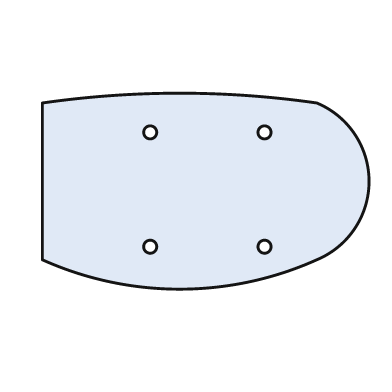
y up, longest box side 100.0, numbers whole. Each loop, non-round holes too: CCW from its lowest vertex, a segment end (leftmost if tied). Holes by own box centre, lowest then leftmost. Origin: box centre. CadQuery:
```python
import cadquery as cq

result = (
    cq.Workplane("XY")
    .moveTo(-50.0, -21.0)
    .threePointArc((-8.0, -30.0), (34.0, -21.0))
    .threePointArc((50.0, 3.0), (34.0, 27.0))
    .threePointArc((-8.0, 30.0), (-50.0, 27.0))
    .close()
    .moveTo(-17.0, -17.0)
    .circle(2.0)
    .moveTo(18.0, -17.0)
    .circle(2.0)
    .moveTo(-17.0, 18.0)
    .circle(2.0)
    .moveTo(18.0, 18.0)
    .circle(2.0)
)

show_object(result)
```